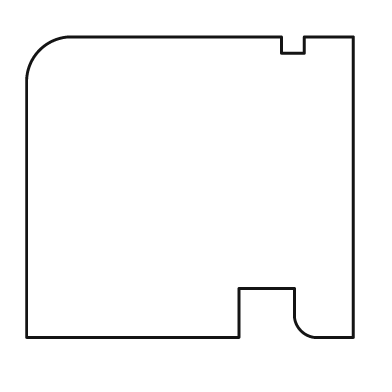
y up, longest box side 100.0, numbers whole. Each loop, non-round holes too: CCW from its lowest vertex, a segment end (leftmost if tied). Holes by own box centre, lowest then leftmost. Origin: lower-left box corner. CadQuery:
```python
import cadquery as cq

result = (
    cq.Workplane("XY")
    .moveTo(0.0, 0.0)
    .lineTo(65.0, 0.0)
    .lineTo(65.0, 15.0)
    .lineTo(82.0, 15.0)
    .lineTo(82.0, 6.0)
    .threePointArc((84.0, 2.0), (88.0, 0.0))
    .lineTo(100.0, 0.0)
    .lineTo(100.0, 92.0)
    .lineTo(85.0, 92.0)
    .lineTo(85.0, 87.0)
    .lineTo(78.0, 87.0)
    .lineTo(78.0, 92.0)
    .lineTo(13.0, 92.0)
    .threePointArc((4.0, 88.0), (0.0, 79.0))
    .close()
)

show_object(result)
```